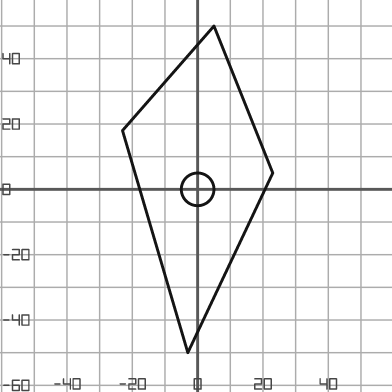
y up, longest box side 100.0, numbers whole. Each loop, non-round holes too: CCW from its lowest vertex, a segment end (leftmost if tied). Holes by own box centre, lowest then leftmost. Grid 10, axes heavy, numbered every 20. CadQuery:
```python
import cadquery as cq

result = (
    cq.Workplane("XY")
    .moveTo(-3.0, -50.0)
    .lineTo(23.0, 5.0)
    .lineTo(5.0, 50.0)
    .lineTo(-23.0, 18.0)
    .close()
    .moveTo(0.0, 0.0)
    .circle(5.0)
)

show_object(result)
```